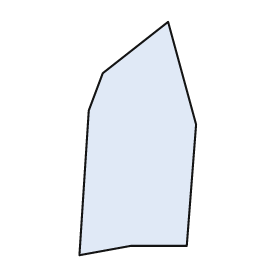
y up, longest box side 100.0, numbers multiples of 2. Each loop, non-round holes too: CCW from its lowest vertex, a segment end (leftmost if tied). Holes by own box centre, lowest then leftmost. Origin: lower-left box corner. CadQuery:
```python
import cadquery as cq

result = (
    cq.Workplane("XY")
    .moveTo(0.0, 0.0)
    .lineTo(22.0, 4.0)
    .lineTo(46.0, 4.0)
    .lineTo(50.0, 56.0)
    .lineTo(38.0, 100.0)
    .lineTo(10.0, 78.0)
    .lineTo(4.0, 62.0)
    .close()
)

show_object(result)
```